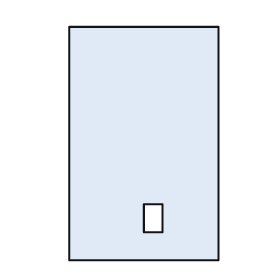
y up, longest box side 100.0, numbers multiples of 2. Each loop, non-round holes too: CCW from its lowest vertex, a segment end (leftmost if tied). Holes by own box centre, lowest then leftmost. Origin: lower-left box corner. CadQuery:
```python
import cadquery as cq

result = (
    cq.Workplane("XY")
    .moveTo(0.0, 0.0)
    .lineTo(64.0, 0.0)
    .lineTo(64.0, 100.0)
    .lineTo(0.0, 100.0)
    .close()
    .moveTo(32.0, 12.0)
    .lineTo(40.0, 12.0)
    .lineTo(40.0, 24.0)
    .lineTo(32.0, 24.0)
    .close()
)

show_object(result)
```